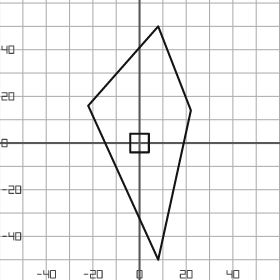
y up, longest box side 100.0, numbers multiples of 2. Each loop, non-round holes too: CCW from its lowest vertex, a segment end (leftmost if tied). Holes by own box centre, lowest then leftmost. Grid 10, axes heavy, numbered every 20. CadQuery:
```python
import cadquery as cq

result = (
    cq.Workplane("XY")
    .moveTo(8.0, -50.0)
    .lineTo(22.0, 14.0)
    .lineTo(8.0, 50.0)
    .lineTo(-22.0, 16.0)
    .close()
    .moveTo(-4.0, -4.0)
    .lineTo(4.0, -4.0)
    .lineTo(4.0, 4.0)
    .lineTo(-4.0, 4.0)
    .close()
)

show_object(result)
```